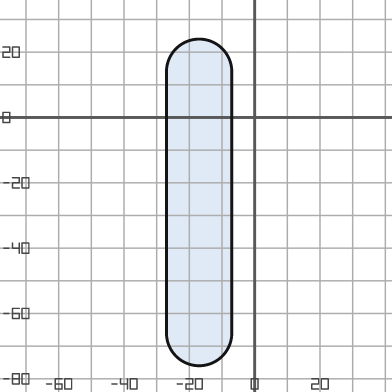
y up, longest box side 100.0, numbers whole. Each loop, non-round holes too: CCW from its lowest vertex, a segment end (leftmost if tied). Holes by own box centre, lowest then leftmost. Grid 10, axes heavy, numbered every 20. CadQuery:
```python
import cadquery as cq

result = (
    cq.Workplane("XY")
    .moveTo(-27.0, -66.0)
    .threePointArc((-17.0, -76.0), (-7.0, -66.0))
    .lineTo(-7.0, 14.0)
    .threePointArc((-17.0, 24.0), (-27.0, 14.0))
    .close()
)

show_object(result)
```